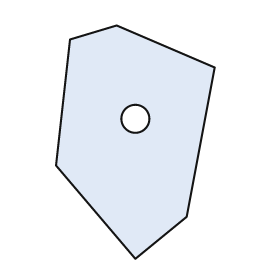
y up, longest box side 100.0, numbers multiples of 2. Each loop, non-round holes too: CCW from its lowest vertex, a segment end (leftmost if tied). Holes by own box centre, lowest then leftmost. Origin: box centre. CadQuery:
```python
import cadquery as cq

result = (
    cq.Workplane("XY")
    .moveTo(0.0, -50.0)
    .lineTo(22.0, -32.0)
    .lineTo(34.0, 32.0)
    .lineTo(-8.0, 50.0)
    .lineTo(-28.0, 44.0)
    .lineTo(-34.0, -10.0)
    .close()
    .moveTo(0.0, 10.0)
    .circle(6.0)
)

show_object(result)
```